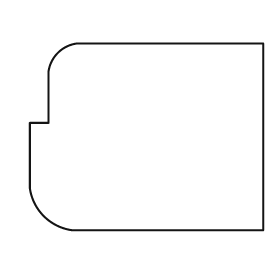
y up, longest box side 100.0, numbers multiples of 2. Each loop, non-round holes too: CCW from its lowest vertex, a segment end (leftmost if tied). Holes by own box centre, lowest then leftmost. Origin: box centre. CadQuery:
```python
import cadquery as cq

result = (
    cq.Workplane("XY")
    .moveTo(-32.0, -40.0)
    .lineTo(50.0, -40.0)
    .lineTo(50.0, 40.0)
    .lineTo(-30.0, 40.0)
    .threePointArc((-38.0, 36.0), (-42.0, 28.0))
    .lineTo(-42.0, 6.0)
    .lineTo(-50.0, 6.0)
    .lineTo(-50.0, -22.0)
    .threePointArc((-44.0, -34.0), (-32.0, -40.0))
    .close()
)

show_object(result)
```